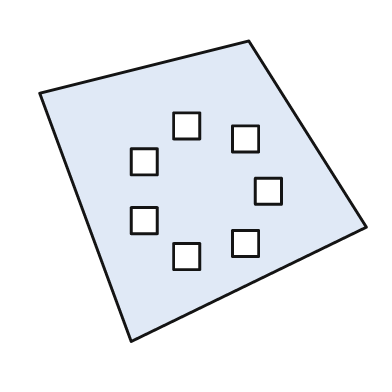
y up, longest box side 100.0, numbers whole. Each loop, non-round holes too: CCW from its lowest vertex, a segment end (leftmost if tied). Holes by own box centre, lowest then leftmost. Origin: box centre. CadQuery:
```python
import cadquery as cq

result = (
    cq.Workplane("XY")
    .moveTo(-22.0, -46.0)
    .lineTo(50.0, -11.0)
    .lineTo(14.0, 46.0)
    .lineTo(-50.0, 30.0)
    .close()
    .moveTo(-9.0, -24.0)
    .lineTo(-1.0, -24.0)
    .lineTo(-1.0, -16.0)
    .lineTo(-9.0, -16.0)
    .close()
    .moveTo(9.0, -20.0)
    .lineTo(17.0, -20.0)
    .lineTo(17.0, -12.0)
    .lineTo(9.0, -12.0)
    .close()
    .moveTo(-22.0, -13.0)
    .lineTo(-14.0, -13.0)
    .lineTo(-14.0, -5.0)
    .lineTo(-22.0, -5.0)
    .close()
    .moveTo(16.0, -4.0)
    .lineTo(24.0, -4.0)
    .lineTo(24.0, 4.0)
    .lineTo(16.0, 4.0)
    .close()
    .moveTo(-22.0, 5.0)
    .lineTo(-14.0, 5.0)
    .lineTo(-14.0, 13.0)
    .lineTo(-22.0, 13.0)
    .close()
    .moveTo(9.0, 12.0)
    .lineTo(17.0, 12.0)
    .lineTo(17.0, 20.0)
    .lineTo(9.0, 20.0)
    .close()
    .moveTo(-9.0, 16.0)
    .lineTo(-1.0, 16.0)
    .lineTo(-1.0, 24.0)
    .lineTo(-9.0, 24.0)
    .close()
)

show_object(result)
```